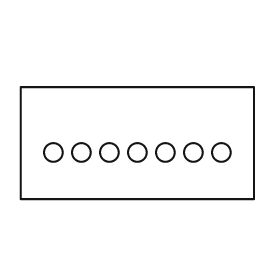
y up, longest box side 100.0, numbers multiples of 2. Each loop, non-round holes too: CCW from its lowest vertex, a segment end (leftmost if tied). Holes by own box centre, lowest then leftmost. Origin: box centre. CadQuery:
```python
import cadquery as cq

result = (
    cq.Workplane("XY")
    .moveTo(-50.0, -24.0)
    .lineTo(50.0, -24.0)
    .lineTo(50.0, 24.0)
    .lineTo(-50.0, 24.0)
    .close()
    .moveTo(-36.0, -4.0)
    .circle(4.0)
    .moveTo(-24.0, -4.0)
    .circle(4.0)
    .moveTo(-12.0, -4.0)
    .circle(4.0)
    .moveTo(0.0, -4.0)
    .circle(4.0)
    .moveTo(12.0, -4.0)
    .circle(4.0)
    .moveTo(24.0, -4.0)
    .circle(4.0)
    .moveTo(36.0, -4.0)
    .circle(4.0)
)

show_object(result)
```